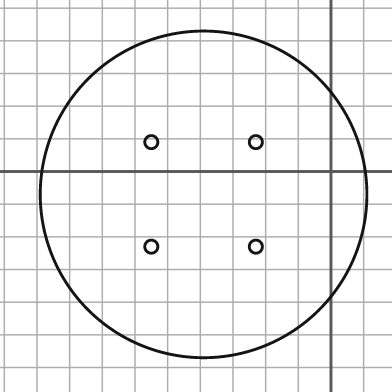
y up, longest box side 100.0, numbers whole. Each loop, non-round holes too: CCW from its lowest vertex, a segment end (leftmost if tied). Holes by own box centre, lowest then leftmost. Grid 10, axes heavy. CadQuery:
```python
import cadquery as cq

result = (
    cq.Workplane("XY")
    .moveTo(-39.0, -7.0)
    .circle(50.0)
    .moveTo(-55.0, -23.0)
    .circle(2.0)
    .moveTo(-23.0, -23.0)
    .circle(2.0)
    .moveTo(-55.0, 9.0)
    .circle(2.0)
    .moveTo(-23.0, 9.0)
    .circle(2.0)
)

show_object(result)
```